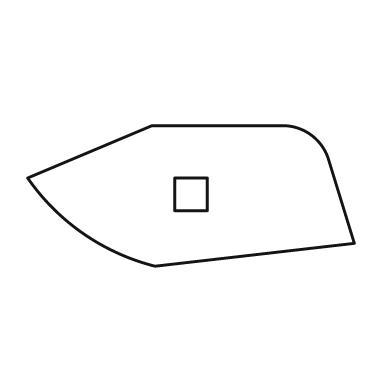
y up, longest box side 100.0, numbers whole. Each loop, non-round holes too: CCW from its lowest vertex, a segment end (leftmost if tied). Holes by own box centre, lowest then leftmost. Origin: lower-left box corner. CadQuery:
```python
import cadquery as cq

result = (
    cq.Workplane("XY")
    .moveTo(39.0, 0.0)
    .lineTo(100.0, 7.0)
    .lineTo(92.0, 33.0)
    .threePointArc((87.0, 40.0), (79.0, 43.0))
    .lineTo(38.0, 43.0)
    .lineTo(0.0, 27.0)
    .threePointArc((17.0, 10.0), (39.0, 0.0))
    .close()
    .moveTo(45.0, 17.0)
    .lineTo(55.0, 17.0)
    .lineTo(55.0, 27.0)
    .lineTo(45.0, 27.0)
    .close()
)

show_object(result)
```